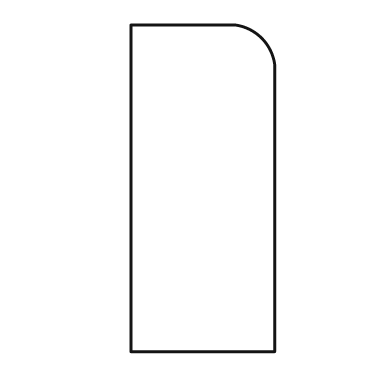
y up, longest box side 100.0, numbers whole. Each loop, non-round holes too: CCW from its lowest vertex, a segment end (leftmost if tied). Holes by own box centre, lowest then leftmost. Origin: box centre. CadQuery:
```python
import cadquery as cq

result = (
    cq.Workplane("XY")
    .moveTo(-22.0, -50.0)
    .lineTo(22.0, -50.0)
    .lineTo(22.0, 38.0)
    .threePointArc((18.0, 46.0), (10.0, 50.0))
    .lineTo(-22.0, 50.0)
    .close()
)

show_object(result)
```